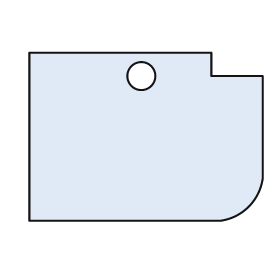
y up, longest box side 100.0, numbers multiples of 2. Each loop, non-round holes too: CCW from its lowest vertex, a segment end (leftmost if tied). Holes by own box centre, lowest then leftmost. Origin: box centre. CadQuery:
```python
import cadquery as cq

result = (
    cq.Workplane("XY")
    .moveTo(-50.0, -36.0)
    .lineTo(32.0, -36.0)
    .threePointArc((44.0, -30.0), (50.0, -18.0))
    .lineTo(50.0, 26.0)
    .lineTo(28.0, 26.0)
    .lineTo(28.0, 36.0)
    .lineTo(-50.0, 36.0)
    .close()
    .moveTo(-2.0, 26.0)
    .circle(6.0)
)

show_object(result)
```